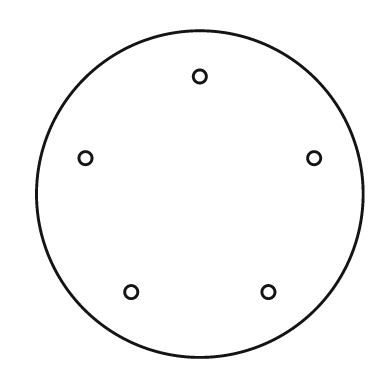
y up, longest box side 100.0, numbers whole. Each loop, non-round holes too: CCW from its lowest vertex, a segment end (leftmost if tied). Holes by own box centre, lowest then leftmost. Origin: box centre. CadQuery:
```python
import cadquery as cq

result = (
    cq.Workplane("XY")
    .moveTo(0.0, 0.0)
    .circle(50.0)
    .moveTo(-21.0, -30.0)
    .circle(2.0)
    .moveTo(21.0, -30.0)
    .circle(2.0)
    .moveTo(-35.0, 11.0)
    .circle(2.0)
    .moveTo(35.0, 11.0)
    .circle(2.0)
    .moveTo(0.0, 36.0)
    .circle(2.0)
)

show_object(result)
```